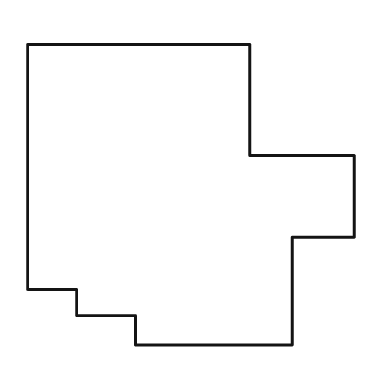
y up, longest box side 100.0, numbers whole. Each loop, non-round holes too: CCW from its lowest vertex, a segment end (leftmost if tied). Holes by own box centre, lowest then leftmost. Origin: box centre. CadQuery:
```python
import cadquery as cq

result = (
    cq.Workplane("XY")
    .moveTo(-17.0, -46.0)
    .lineTo(31.0, -46.0)
    .lineTo(31.0, -13.0)
    .lineTo(50.0, -13.0)
    .lineTo(50.0, 12.0)
    .lineTo(18.0, 12.0)
    .lineTo(18.0, 46.0)
    .lineTo(-50.0, 46.0)
    .lineTo(-50.0, -29.0)
    .lineTo(-35.0, -29.0)
    .lineTo(-35.0, -37.0)
    .lineTo(-17.0, -37.0)
    .close()
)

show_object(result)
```